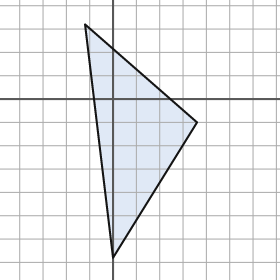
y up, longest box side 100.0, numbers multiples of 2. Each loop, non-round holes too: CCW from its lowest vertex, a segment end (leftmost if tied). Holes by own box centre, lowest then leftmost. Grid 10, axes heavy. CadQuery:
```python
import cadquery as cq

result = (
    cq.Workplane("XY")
    .moveTo(0.0, -68.0)
    .lineTo(36.0, -10.0)
    .lineTo(-12.0, 32.0)
    .close()
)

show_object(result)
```